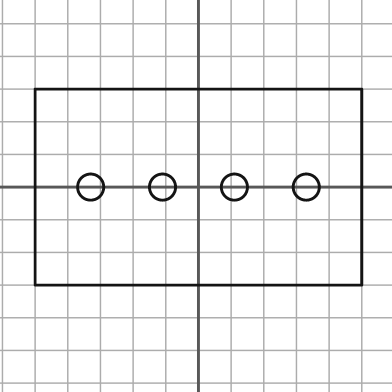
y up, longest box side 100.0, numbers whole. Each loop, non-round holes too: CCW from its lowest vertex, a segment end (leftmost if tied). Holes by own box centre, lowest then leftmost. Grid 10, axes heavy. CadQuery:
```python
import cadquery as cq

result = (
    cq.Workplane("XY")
    .moveTo(-50.0, -30.0)
    .lineTo(50.0, -30.0)
    .lineTo(50.0, 30.0)
    .lineTo(-50.0, 30.0)
    .close()
    .moveTo(-33.0, 0.0)
    .circle(4.0)
    .moveTo(-11.0, 0.0)
    .circle(4.0)
    .moveTo(11.0, 0.0)
    .circle(4.0)
    .moveTo(33.0, 0.0)
    .circle(4.0)
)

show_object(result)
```